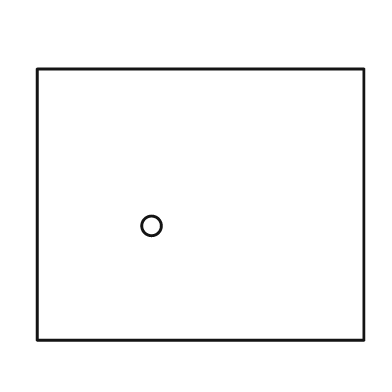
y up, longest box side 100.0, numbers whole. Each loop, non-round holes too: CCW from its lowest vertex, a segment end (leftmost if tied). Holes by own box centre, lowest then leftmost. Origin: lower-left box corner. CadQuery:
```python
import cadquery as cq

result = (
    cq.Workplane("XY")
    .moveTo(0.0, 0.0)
    .lineTo(100.0, 0.0)
    .lineTo(100.0, 83.0)
    .lineTo(0.0, 83.0)
    .close()
    .moveTo(35.0, 35.0)
    .circle(3.0)
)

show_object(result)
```